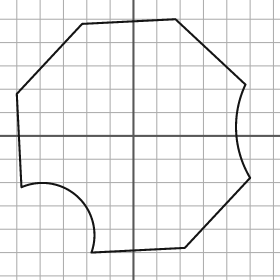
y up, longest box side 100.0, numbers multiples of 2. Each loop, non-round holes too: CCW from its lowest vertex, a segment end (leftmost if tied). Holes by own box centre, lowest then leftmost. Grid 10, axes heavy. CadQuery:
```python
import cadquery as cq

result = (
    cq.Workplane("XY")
    .moveTo(-18.0, -50.0)
    .lineTo(22.0, -48.0)
    .lineTo(50.0, -18.0)
    .threePointArc((44.0, 2.0), (48.0, 22.0))
    .lineTo(18.0, 50.0)
    .lineTo(-22.0, 48.0)
    .lineTo(-50.0, 18.0)
    .lineTo(-48.0, -22.0)
    .threePointArc((-24.0, -26.0), (-18.0, -50.0))
    .close()
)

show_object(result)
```